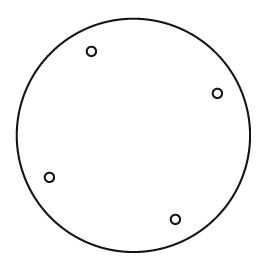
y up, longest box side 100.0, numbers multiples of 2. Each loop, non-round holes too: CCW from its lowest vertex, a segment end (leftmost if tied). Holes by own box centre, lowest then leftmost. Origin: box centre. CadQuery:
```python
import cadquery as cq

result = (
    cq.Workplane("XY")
    .moveTo(0.0, 0.0)
    .circle(50.0)
    .moveTo(18.0, -36.0)
    .circle(2.0)
    .moveTo(-36.0, -18.0)
    .circle(2.0)
    .moveTo(36.0, 18.0)
    .circle(2.0)
    .moveTo(-18.0, 36.0)
    .circle(2.0)
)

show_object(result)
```